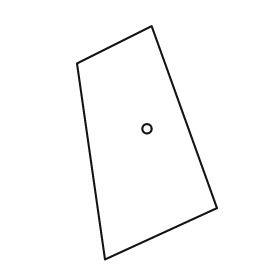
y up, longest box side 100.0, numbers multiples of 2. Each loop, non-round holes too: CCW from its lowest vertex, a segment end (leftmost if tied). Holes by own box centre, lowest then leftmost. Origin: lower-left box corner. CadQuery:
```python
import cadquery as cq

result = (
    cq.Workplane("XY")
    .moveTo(12.0, 0.0)
    .lineTo(60.0, 22.0)
    .lineTo(32.0, 100.0)
    .lineTo(0.0, 84.0)
    .close()
    .moveTo(30.0, 56.0)
    .circle(2.0)
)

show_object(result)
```